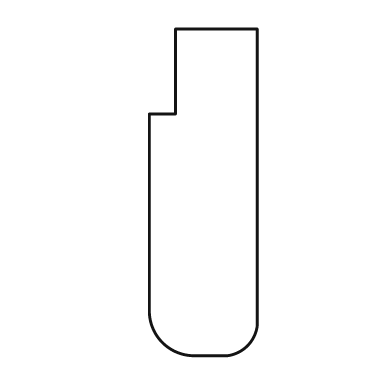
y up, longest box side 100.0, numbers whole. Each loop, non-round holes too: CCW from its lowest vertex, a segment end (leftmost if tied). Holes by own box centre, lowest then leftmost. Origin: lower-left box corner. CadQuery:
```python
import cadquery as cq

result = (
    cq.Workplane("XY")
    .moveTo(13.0, 0.0)
    .lineTo(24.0, 0.0)
    .threePointArc((30.0, 3.0), (33.0, 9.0))
    .lineTo(33.0, 100.0)
    .lineTo(8.0, 100.0)
    .lineTo(8.0, 74.0)
    .lineTo(0.0, 74.0)
    .lineTo(0.0, 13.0)
    .threePointArc((4.0, 4.0), (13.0, 0.0))
    .close()
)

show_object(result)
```